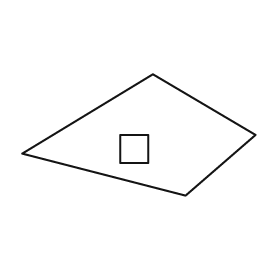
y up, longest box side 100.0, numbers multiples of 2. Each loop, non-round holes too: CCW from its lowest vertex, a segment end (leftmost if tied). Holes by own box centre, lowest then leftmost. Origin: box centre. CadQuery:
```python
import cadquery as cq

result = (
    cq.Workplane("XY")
    .moveTo(20.0, -26.0)
    .lineTo(50.0, 0.0)
    .lineTo(6.0, 26.0)
    .lineTo(-50.0, -8.0)
    .close()
    .moveTo(-8.0, -12.0)
    .lineTo(4.0, -12.0)
    .lineTo(4.0, 0.0)
    .lineTo(-8.0, 0.0)
    .close()
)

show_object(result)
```